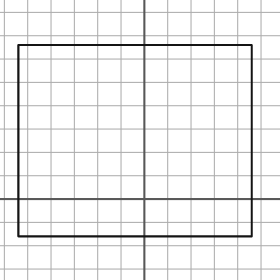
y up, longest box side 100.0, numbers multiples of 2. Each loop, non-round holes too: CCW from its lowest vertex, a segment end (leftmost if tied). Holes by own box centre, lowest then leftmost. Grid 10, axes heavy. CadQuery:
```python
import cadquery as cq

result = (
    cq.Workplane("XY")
    .moveTo(-54.0, -16.0)
    .lineTo(46.0, -16.0)
    .lineTo(46.0, 66.0)
    .lineTo(-54.0, 66.0)
    .close()
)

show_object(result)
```